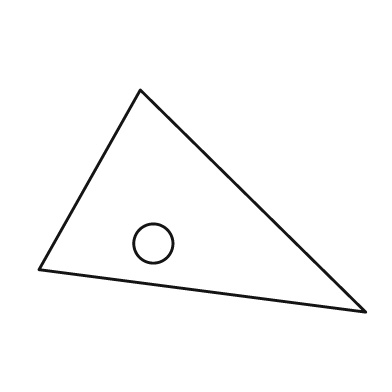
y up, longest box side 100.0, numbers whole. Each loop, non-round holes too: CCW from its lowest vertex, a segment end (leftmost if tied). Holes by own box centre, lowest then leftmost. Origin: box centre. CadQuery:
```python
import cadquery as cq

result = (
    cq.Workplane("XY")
    .moveTo(50.0, -34.0)
    .lineTo(-19.0, 34.0)
    .lineTo(-50.0, -21.0)
    .close()
    .moveTo(-15.0, -13.0)
    .circle(6.0)
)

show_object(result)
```